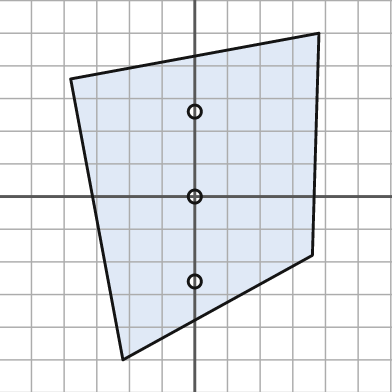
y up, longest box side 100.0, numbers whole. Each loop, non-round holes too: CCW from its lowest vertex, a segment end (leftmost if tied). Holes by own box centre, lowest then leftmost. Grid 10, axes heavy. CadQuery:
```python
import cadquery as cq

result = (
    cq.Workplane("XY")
    .moveTo(-22.0, -50.0)
    .lineTo(36.0, -18.0)
    .lineTo(38.0, 50.0)
    .lineTo(-38.0, 36.0)
    .close()
    .moveTo(0.0, -26.0)
    .circle(2.0)
    .moveTo(0.0, 0.0)
    .circle(2.0)
    .moveTo(0.0, 26.0)
    .circle(2.0)
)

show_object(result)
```